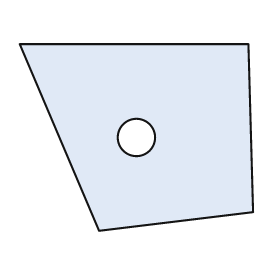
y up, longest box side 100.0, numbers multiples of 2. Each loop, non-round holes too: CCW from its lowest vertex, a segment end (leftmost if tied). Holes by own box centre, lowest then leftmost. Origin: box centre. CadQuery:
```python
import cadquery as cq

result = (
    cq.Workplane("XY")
    .moveTo(-16.0, -40.0)
    .lineTo(50.0, -32.0)
    .lineTo(48.0, 40.0)
    .lineTo(-50.0, 40.0)
    .close()
    .moveTo(0.0, 0.0)
    .circle(8.0)
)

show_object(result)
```